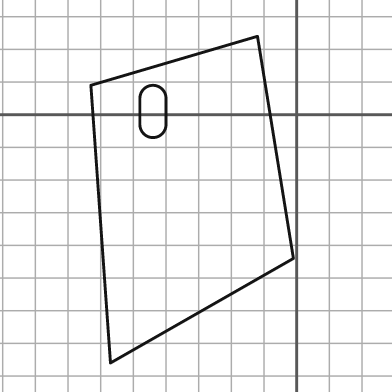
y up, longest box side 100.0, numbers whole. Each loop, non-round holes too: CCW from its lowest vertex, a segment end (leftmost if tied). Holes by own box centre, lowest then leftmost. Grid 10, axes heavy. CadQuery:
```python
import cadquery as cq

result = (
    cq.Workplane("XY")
    .moveTo(-57.0, -76.0)
    .lineTo(-1.0, -44.0)
    .lineTo(-12.0, 24.0)
    .lineTo(-63.0, 9.0)
    .close()
    .moveTo(-48.0, -3.0)
    .threePointArc((-44.0, -7.0), (-40.0, -3.0))
    .lineTo(-40.0, 5.0)
    .threePointArc((-44.0, 9.0), (-48.0, 5.0))
    .close()
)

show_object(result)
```